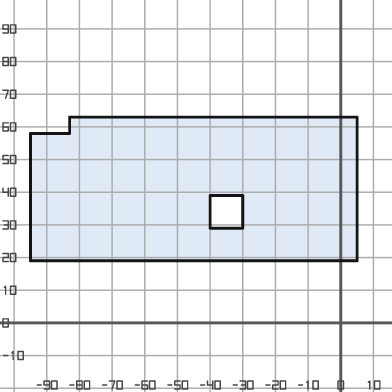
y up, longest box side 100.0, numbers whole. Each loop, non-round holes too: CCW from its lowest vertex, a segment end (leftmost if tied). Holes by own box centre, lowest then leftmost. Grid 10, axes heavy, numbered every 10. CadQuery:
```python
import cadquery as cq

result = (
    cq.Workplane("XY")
    .moveTo(-95.0, 19.0)
    .lineTo(5.0, 19.0)
    .lineTo(5.0, 63.0)
    .lineTo(-83.0, 63.0)
    .lineTo(-83.0, 58.0)
    .lineTo(-95.0, 58.0)
    .close()
    .moveTo(-40.0, 29.0)
    .lineTo(-30.0, 29.0)
    .lineTo(-30.0, 39.0)
    .lineTo(-40.0, 39.0)
    .close()
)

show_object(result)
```